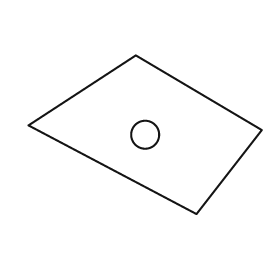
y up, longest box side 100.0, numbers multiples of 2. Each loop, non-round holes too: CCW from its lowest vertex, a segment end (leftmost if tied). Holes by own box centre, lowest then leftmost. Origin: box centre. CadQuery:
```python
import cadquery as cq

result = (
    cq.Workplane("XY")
    .moveTo(22.0, -34.0)
    .lineTo(50.0, 2.0)
    .lineTo(-4.0, 34.0)
    .lineTo(-50.0, 4.0)
    .close()
    .moveTo(0.0, 0.0)
    .circle(6.0)
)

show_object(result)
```